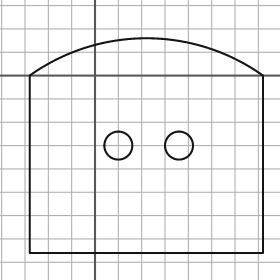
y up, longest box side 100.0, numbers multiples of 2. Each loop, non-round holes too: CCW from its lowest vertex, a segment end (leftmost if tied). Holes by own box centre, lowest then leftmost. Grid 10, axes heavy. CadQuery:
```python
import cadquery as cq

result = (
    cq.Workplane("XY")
    .moveTo(-28.0, -76.0)
    .lineTo(72.0, -76.0)
    .lineTo(72.0, 0.0)
    .threePointArc((22.0, 16.0), (-28.0, 0.0))
    .close()
    .moveTo(10.0, -30.0)
    .circle(6.0)
    .moveTo(36.0, -30.0)
    .circle(6.0)
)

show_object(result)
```